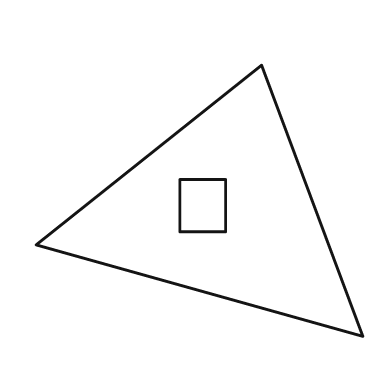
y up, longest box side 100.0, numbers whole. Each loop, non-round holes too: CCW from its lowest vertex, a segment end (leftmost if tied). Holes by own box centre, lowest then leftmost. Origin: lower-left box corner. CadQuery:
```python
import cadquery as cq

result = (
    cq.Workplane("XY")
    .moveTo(100.0, 0.0)
    .lineTo(69.0, 83.0)
    .lineTo(0.0, 28.0)
    .close()
    .moveTo(44.0, 32.0)
    .lineTo(58.0, 32.0)
    .lineTo(58.0, 48.0)
    .lineTo(44.0, 48.0)
    .close()
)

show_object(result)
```